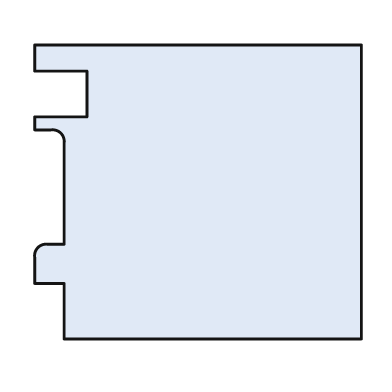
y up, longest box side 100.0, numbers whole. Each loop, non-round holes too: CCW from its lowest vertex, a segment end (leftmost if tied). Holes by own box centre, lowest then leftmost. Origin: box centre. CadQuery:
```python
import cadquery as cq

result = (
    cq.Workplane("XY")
    .moveTo(-41.0, -45.0)
    .lineTo(50.0, -45.0)
    .lineTo(50.0, 45.0)
    .lineTo(-50.0, 45.0)
    .lineTo(-50.0, 37.0)
    .lineTo(-34.0, 37.0)
    .lineTo(-34.0, 23.0)
    .lineTo(-50.0, 23.0)
    .lineTo(-50.0, 19.0)
    .lineTo(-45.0, 19.0)
    .threePointArc((-42.0, 18.0), (-41.0, 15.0))
    .lineTo(-41.0, -16.0)
    .lineTo(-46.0, -16.0)
    .threePointArc((-49.0, -17.0), (-50.0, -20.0))
    .lineTo(-50.0, -28.0)
    .lineTo(-41.0, -28.0)
    .close()
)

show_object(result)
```